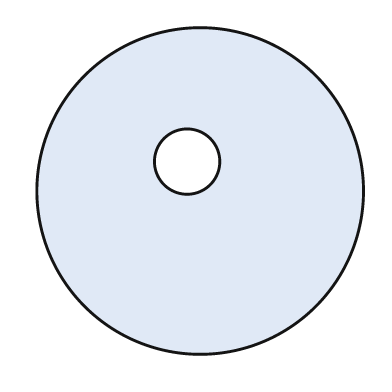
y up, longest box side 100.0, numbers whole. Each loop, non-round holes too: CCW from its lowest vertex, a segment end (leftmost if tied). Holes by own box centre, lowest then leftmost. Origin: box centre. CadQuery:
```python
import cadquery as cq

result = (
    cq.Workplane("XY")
    .moveTo(0.0, 0.0)
    .circle(50.0)
    .moveTo(-4.0, 9.0)
    .circle(10.0)
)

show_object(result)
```